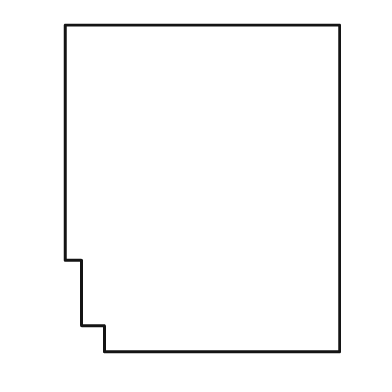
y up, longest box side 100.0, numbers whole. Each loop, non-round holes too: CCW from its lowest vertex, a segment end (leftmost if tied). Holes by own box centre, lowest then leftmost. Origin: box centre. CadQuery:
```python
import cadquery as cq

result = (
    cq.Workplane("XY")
    .moveTo(-30.0, -50.0)
    .lineTo(42.0, -50.0)
    .lineTo(42.0, 50.0)
    .lineTo(-42.0, 50.0)
    .lineTo(-42.0, -22.0)
    .lineTo(-37.0, -22.0)
    .lineTo(-37.0, -42.0)
    .lineTo(-30.0, -42.0)
    .close()
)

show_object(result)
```